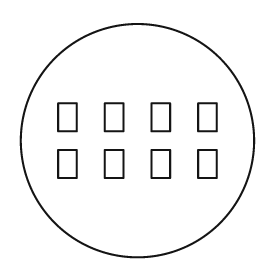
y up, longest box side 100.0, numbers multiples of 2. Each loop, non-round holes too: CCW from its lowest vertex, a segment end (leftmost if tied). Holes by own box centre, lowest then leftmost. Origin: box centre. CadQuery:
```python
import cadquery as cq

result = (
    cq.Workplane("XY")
    .moveTo(0.0, 0.0)
    .circle(50.0)
    .moveTo(-34.0, -16.0)
    .lineTo(-26.0, -16.0)
    .lineTo(-26.0, -4.0)
    .lineTo(-34.0, -4.0)
    .close()
    .moveTo(-14.0, -16.0)
    .lineTo(-6.0, -16.0)
    .lineTo(-6.0, -4.0)
    .lineTo(-14.0, -4.0)
    .close()
    .moveTo(6.0, -16.0)
    .lineTo(14.0, -16.0)
    .lineTo(14.0, -4.0)
    .lineTo(6.0, -4.0)
    .close()
    .moveTo(26.0, -16.0)
    .lineTo(34.0, -16.0)
    .lineTo(34.0, -4.0)
    .lineTo(26.0, -4.0)
    .close()
    .moveTo(-34.0, 4.0)
    .lineTo(-26.0, 4.0)
    .lineTo(-26.0, 16.0)
    .lineTo(-34.0, 16.0)
    .close()
    .moveTo(-14.0, 4.0)
    .lineTo(-6.0, 4.0)
    .lineTo(-6.0, 16.0)
    .lineTo(-14.0, 16.0)
    .close()
    .moveTo(6.0, 4.0)
    .lineTo(14.0, 4.0)
    .lineTo(14.0, 16.0)
    .lineTo(6.0, 16.0)
    .close()
    .moveTo(26.0, 4.0)
    .lineTo(34.0, 4.0)
    .lineTo(34.0, 16.0)
    .lineTo(26.0, 16.0)
    .close()
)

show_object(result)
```